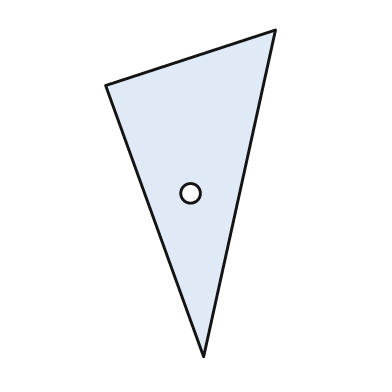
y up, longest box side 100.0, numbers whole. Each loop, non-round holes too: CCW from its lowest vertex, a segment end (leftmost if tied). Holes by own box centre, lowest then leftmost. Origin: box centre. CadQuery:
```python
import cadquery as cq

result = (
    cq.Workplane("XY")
    .moveTo(4.0, -50.0)
    .lineTo(26.0, 50.0)
    .lineTo(-26.0, 33.0)
    .close()
    .moveTo(0.0, 0.0)
    .circle(3.0)
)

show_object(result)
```